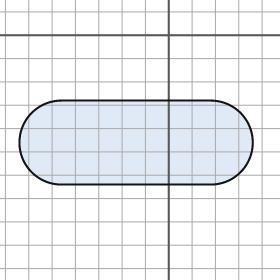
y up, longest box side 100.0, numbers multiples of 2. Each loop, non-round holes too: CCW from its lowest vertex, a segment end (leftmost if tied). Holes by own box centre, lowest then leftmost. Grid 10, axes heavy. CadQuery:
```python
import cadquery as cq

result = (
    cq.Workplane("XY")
    .moveTo(-46.0, -64.0)
    .lineTo(18.0, -64.0)
    .threePointArc((36.0, -46.0), (18.0, -28.0))
    .lineTo(-46.0, -28.0)
    .threePointArc((-64.0, -46.0), (-46.0, -64.0))
    .close()
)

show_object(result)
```